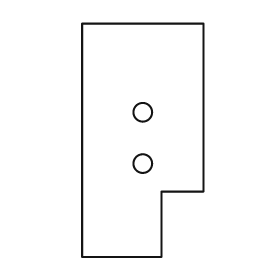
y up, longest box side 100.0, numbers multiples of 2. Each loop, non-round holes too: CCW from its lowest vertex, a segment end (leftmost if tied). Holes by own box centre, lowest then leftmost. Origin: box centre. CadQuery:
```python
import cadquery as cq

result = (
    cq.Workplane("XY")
    .moveTo(-26.0, -50.0)
    .lineTo(8.0, -50.0)
    .lineTo(8.0, -22.0)
    .lineTo(26.0, -22.0)
    .lineTo(26.0, 50.0)
    .lineTo(-26.0, 50.0)
    .close()
    .moveTo(0.0, -10.0)
    .circle(4.0)
    .moveTo(0.0, 12.0)
    .circle(4.0)
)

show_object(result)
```